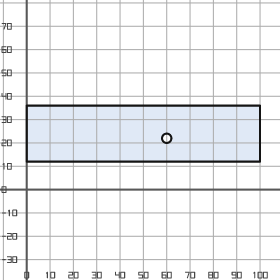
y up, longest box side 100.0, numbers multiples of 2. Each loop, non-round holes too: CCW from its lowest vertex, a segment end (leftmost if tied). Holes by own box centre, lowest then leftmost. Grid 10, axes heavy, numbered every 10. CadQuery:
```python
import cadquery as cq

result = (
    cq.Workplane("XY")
    .moveTo(0.0, 12.0)
    .lineTo(100.0, 12.0)
    .lineTo(100.0, 36.0)
    .lineTo(0.0, 36.0)
    .close()
    .moveTo(60.0, 22.0)
    .circle(2.0)
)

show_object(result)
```